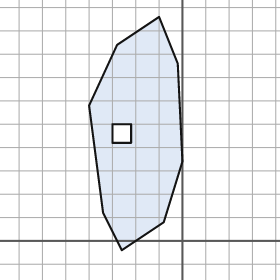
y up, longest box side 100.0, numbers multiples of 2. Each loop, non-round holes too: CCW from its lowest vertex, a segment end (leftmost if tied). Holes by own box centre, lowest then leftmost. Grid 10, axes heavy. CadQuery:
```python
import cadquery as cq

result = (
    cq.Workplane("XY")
    .moveTo(-26.0, -4.0)
    .lineTo(-8.0, 8.0)
    .lineTo(0.0, 34.0)
    .lineTo(-2.0, 76.0)
    .lineTo(-10.0, 96.0)
    .lineTo(-28.0, 84.0)
    .lineTo(-40.0, 58.0)
    .lineTo(-34.0, 12.0)
    .close()
    .moveTo(-30.0, 42.0)
    .lineTo(-22.0, 42.0)
    .lineTo(-22.0, 50.0)
    .lineTo(-30.0, 50.0)
    .close()
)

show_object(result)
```